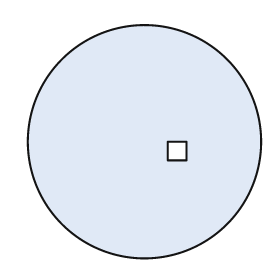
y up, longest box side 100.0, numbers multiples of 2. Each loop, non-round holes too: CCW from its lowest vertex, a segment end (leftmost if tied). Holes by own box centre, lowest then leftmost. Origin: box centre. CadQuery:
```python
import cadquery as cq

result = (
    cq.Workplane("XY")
    .moveTo(0.0, 0.0)
    .circle(50.0)
    .moveTo(10.0, -8.0)
    .lineTo(18.0, -8.0)
    .lineTo(18.0, 0.0)
    .lineTo(10.0, 0.0)
    .close()
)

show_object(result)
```